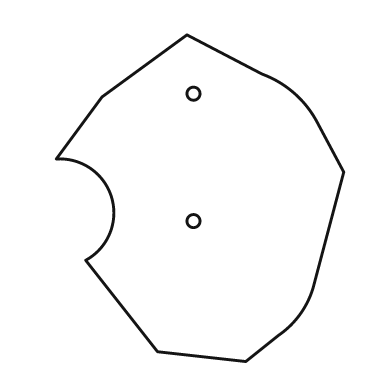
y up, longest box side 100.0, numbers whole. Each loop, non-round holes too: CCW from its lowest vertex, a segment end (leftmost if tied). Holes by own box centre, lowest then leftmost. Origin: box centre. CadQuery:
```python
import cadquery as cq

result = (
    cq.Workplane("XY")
    .moveTo(14.0, -50.0)
    .lineTo(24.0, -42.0)
    .threePointArc((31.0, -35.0), (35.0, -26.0))
    .lineTo(44.0, 8.0)
    .lineTo(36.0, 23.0)
    .threePointArc((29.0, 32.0), (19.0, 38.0))
    .lineTo(-4.0, 50.0)
    .lineTo(-30.0, 31.0)
    .lineTo(-44.0, 12.0)
    .threePointArc((-27.0, 0.0), (-35.0, -19.0))
    .lineTo(-13.0, -47.0)
    .close()
    .moveTo(-2.0, -7.0)
    .circle(2.0)
    .moveTo(-2.0, 32.0)
    .circle(2.0)
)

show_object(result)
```